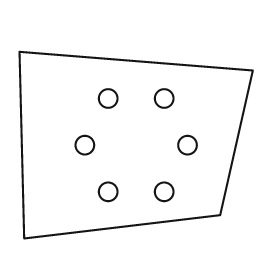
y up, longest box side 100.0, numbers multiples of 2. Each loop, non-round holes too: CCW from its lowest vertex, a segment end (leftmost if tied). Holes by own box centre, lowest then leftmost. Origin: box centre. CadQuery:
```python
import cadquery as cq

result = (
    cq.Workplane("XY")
    .moveTo(-48.0, -40.0)
    .lineTo(36.0, -30.0)
    .lineTo(50.0, 32.0)
    .lineTo(-50.0, 40.0)
    .close()
    .moveTo(-12.0, -20.0)
    .circle(4.0)
    .moveTo(12.0, -20.0)
    .circle(4.0)
    .moveTo(-22.0, 0.0)
    .circle(4.0)
    .moveTo(22.0, 0.0)
    .circle(4.0)
    .moveTo(-12.0, 20.0)
    .circle(4.0)
    .moveTo(12.0, 20.0)
    .circle(4.0)
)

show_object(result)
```